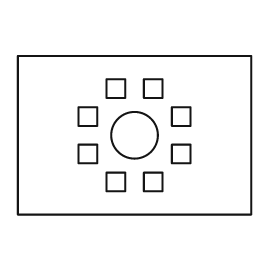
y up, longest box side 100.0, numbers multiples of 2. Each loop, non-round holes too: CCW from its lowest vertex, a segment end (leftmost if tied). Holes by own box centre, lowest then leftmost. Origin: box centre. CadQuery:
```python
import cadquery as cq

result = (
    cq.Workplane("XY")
    .moveTo(-50.0, -34.0)
    .lineTo(50.0, -34.0)
    .lineTo(50.0, 34.0)
    .lineTo(-50.0, 34.0)
    .close()
    .moveTo(-12.0, -24.0)
    .lineTo(-4.0, -24.0)
    .lineTo(-4.0, -16.0)
    .lineTo(-12.0, -16.0)
    .close()
    .moveTo(4.0, -24.0)
    .lineTo(12.0, -24.0)
    .lineTo(12.0, -16.0)
    .lineTo(4.0, -16.0)
    .close()
    .moveTo(-24.0, -12.0)
    .lineTo(-16.0, -12.0)
    .lineTo(-16.0, -4.0)
    .lineTo(-24.0, -4.0)
    .close()
    .moveTo(16.0, -12.0)
    .lineTo(24.0, -12.0)
    .lineTo(24.0, -4.0)
    .lineTo(16.0, -4.0)
    .close()
    .moveTo(0.0, 0.0)
    .circle(10.0)
    .moveTo(-24.0, 4.0)
    .lineTo(-16.0, 4.0)
    .lineTo(-16.0, 12.0)
    .lineTo(-24.0, 12.0)
    .close()
    .moveTo(16.0, 4.0)
    .lineTo(24.0, 4.0)
    .lineTo(24.0, 12.0)
    .lineTo(16.0, 12.0)
    .close()
    .moveTo(-12.0, 16.0)
    .lineTo(-4.0, 16.0)
    .lineTo(-4.0, 24.0)
    .lineTo(-12.0, 24.0)
    .close()
    .moveTo(4.0, 16.0)
    .lineTo(12.0, 16.0)
    .lineTo(12.0, 24.0)
    .lineTo(4.0, 24.0)
    .close()
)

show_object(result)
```